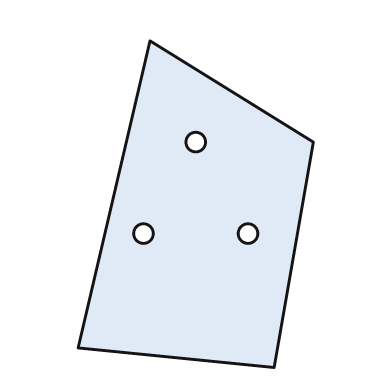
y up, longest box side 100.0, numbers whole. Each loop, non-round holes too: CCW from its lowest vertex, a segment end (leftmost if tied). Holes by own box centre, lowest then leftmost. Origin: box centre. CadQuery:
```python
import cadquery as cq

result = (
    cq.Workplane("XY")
    .moveTo(24.0, -50.0)
    .lineTo(36.0, 19.0)
    .lineTo(-14.0, 50.0)
    .lineTo(-36.0, -44.0)
    .close()
    .moveTo(-16.0, -9.0)
    .circle(3.0)
    .moveTo(16.0, -9.0)
    .circle(3.0)
    .moveTo(0.0, 19.0)
    .circle(3.0)
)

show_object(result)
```